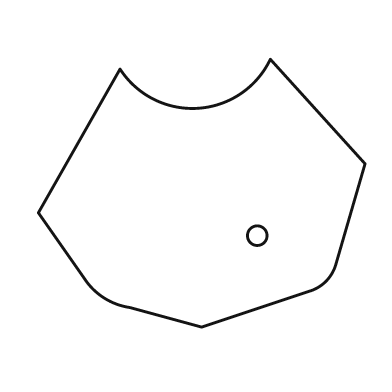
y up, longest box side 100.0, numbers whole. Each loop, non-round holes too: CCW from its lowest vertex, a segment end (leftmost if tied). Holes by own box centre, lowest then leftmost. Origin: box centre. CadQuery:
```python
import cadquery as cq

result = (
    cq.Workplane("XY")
    .moveTo(0.0, -41.0)
    .lineTo(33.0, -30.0)
    .threePointArc((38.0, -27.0), (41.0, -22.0))
    .lineTo(50.0, 9.0)
    .lineTo(21.0, 41.0)
    .threePointArc((-1.0, 26.0), (-25.0, 38.0))
    .lineTo(-50.0, -6.0)
    .lineTo(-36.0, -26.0)
    .threePointArc((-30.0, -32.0), (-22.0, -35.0))
    .close()
    .moveTo(17.0, -13.0)
    .circle(3.0)
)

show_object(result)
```